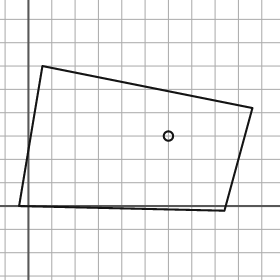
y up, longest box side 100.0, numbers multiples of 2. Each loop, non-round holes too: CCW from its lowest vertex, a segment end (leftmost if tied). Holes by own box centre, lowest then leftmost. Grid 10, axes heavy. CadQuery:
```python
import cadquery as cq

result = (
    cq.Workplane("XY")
    .moveTo(84.0, -2.0)
    .lineTo(96.0, 42.0)
    .lineTo(6.0, 60.0)
    .lineTo(-4.0, 0.0)
    .close()
    .moveTo(60.0, 30.0)
    .circle(2.0)
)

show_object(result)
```